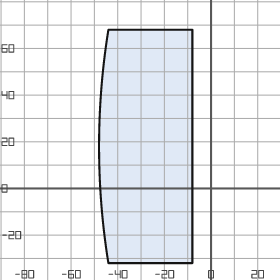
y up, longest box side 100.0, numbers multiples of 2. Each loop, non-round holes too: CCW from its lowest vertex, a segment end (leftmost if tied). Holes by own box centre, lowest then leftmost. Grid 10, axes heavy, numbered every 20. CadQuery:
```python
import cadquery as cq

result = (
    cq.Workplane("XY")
    .moveTo(-44.0, -32.0)
    .lineTo(-8.0, -32.0)
    .lineTo(-8.0, 68.0)
    .lineTo(-44.0, 68.0)
    .threePointArc((-48.0, 18.0), (-44.0, -32.0))
    .close()
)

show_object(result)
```